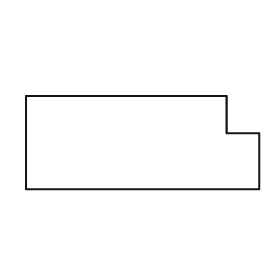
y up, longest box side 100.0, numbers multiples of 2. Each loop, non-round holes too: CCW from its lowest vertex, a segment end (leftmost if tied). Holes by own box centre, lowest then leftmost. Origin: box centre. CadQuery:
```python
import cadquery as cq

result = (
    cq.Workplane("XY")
    .moveTo(-50.0, -20.0)
    .lineTo(50.0, -20.0)
    .lineTo(50.0, 4.0)
    .lineTo(36.0, 4.0)
    .lineTo(36.0, 20.0)
    .lineTo(-50.0, 20.0)
    .close()
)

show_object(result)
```